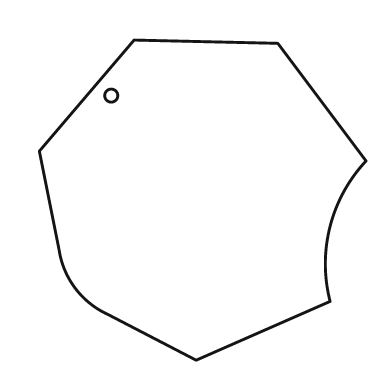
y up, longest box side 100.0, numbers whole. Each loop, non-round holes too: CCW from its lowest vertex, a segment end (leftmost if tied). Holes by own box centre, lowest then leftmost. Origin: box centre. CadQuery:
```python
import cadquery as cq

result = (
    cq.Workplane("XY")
    .moveTo(-2.0, -49.0)
    .lineTo(39.0, -31.0)
    .threePointArc((39.0, -8.0), (50.0, 12.0))
    .lineTo(23.0, 48.0)
    .lineTo(-21.0, 49.0)
    .lineTo(-50.0, 15.0)
    .lineTo(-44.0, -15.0)
    .threePointArc((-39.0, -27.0), (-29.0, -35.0))
    .close()
    .moveTo(-28.0, 32.0)
    .circle(2.0)
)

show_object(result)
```